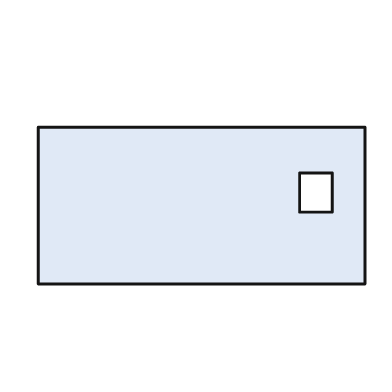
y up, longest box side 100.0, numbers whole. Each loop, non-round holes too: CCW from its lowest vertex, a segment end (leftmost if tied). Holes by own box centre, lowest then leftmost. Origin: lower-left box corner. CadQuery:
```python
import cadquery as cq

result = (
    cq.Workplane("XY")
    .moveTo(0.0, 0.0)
    .lineTo(100.0, 0.0)
    .lineTo(100.0, 48.0)
    .lineTo(0.0, 48.0)
    .close()
    .moveTo(80.0, 22.0)
    .lineTo(90.0, 22.0)
    .lineTo(90.0, 34.0)
    .lineTo(80.0, 34.0)
    .close()
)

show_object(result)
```